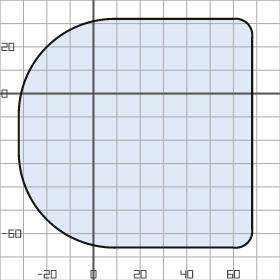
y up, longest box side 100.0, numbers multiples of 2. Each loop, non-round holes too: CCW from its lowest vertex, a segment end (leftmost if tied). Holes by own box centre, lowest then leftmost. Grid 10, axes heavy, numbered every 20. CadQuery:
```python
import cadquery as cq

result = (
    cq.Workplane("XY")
    .moveTo(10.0, -66.0)
    .lineTo(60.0, -66.0)
    .threePointArc((66.0, -64.0), (68.0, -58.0))
    .lineTo(68.0, 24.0)
    .threePointArc((66.0, 30.0), (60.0, 32.0))
    .lineTo(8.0, 32.0)
    .threePointArc((-20.0, 20.0), (-32.0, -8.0))
    .lineTo(-32.0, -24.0)
    .threePointArc((-20.0, -54.0), (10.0, -66.0))
    .close()
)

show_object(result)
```